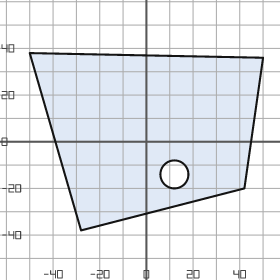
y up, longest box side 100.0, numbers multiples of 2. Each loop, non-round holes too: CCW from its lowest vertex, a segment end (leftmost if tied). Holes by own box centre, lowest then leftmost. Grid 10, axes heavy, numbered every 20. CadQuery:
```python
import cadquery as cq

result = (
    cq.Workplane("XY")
    .moveTo(-28.0, -38.0)
    .lineTo(42.0, -20.0)
    .lineTo(50.0, 36.0)
    .lineTo(-50.0, 38.0)
    .close()
    .moveTo(12.0, -14.0)
    .circle(6.0)
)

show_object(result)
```